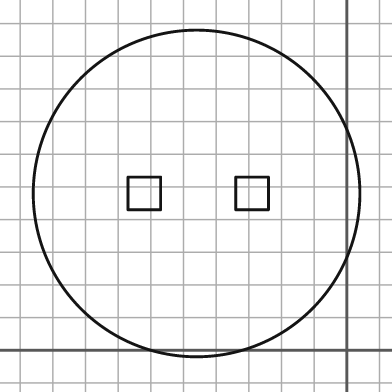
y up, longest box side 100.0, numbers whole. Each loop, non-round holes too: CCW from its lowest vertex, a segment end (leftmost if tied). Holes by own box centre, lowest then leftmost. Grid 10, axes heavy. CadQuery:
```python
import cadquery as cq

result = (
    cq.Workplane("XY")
    .moveTo(-46.0, 48.0)
    .circle(50.0)
    .moveTo(-67.0, 43.0)
    .lineTo(-57.0, 43.0)
    .lineTo(-57.0, 53.0)
    .lineTo(-67.0, 53.0)
    .close()
    .moveTo(-34.0, 43.0)
    .lineTo(-24.0, 43.0)
    .lineTo(-24.0, 53.0)
    .lineTo(-34.0, 53.0)
    .close()
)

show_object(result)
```